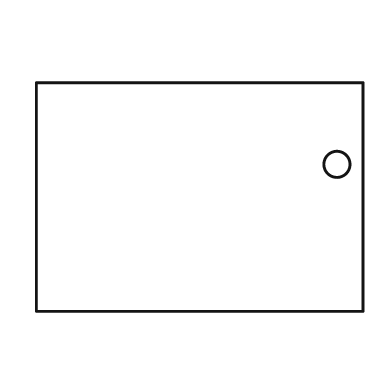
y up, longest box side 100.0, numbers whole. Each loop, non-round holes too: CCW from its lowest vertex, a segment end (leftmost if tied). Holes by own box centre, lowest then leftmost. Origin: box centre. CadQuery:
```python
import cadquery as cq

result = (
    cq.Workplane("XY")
    .moveTo(-50.0, -35.0)
    .lineTo(50.0, -35.0)
    .lineTo(50.0, 35.0)
    .lineTo(-50.0, 35.0)
    .close()
    .moveTo(42.0, 10.0)
    .circle(4.0)
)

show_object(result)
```